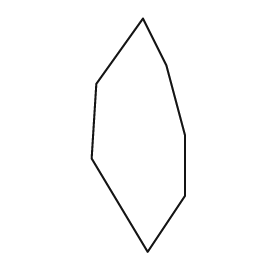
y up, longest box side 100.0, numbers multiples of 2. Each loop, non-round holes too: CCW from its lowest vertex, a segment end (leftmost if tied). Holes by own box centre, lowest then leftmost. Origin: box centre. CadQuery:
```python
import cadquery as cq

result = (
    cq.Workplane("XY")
    .moveTo(4.0, -50.0)
    .lineTo(20.0, -26.0)
    .lineTo(20.0, 0.0)
    .lineTo(12.0, 30.0)
    .lineTo(2.0, 50.0)
    .lineTo(-18.0, 22.0)
    .lineTo(-20.0, -10.0)
    .close()
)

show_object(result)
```